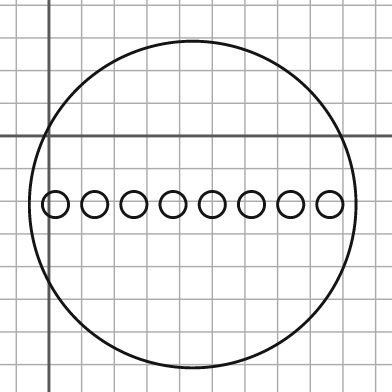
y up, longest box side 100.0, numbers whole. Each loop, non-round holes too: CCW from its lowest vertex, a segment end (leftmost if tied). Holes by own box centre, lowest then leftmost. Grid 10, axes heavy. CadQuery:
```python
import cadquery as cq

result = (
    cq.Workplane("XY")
    .moveTo(44.0, -21.0)
    .circle(50.0)
    .moveTo(2.0, -21.0)
    .circle(4.0)
    .moveTo(14.0, -21.0)
    .circle(4.0)
    .moveTo(26.0, -21.0)
    .circle(4.0)
    .moveTo(38.0, -21.0)
    .circle(4.0)
    .moveTo(50.0, -21.0)
    .circle(4.0)
    .moveTo(62.0, -21.0)
    .circle(4.0)
    .moveTo(74.0, -21.0)
    .circle(4.0)
    .moveTo(86.0, -21.0)
    .circle(4.0)
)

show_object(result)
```